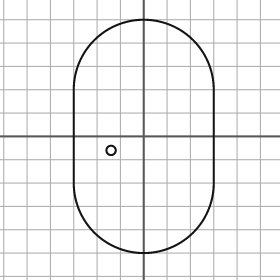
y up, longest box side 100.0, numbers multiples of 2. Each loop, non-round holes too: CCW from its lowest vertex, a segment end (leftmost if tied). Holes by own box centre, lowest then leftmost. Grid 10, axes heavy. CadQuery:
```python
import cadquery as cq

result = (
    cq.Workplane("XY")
    .moveTo(-30.0, -20.0)
    .threePointArc((0.0, -50.0), (30.0, -20.0))
    .lineTo(30.0, 20.0)
    .threePointArc((0.0, 50.0), (-30.0, 20.0))
    .close()
    .moveTo(-14.0, -6.0)
    .circle(2.0)
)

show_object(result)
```